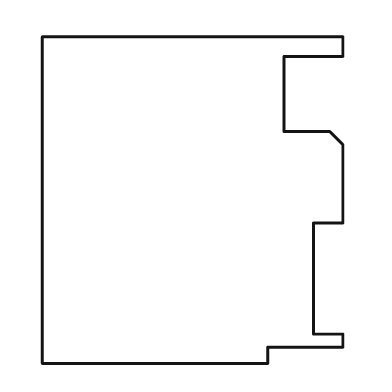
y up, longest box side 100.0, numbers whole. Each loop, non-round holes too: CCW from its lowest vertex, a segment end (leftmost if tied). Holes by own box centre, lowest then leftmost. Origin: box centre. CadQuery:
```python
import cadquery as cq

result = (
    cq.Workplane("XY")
    .moveTo(-46.0, -50.0)
    .lineTo(23.0, -50.0)
    .lineTo(23.0, -45.0)
    .lineTo(46.0, -45.0)
    .lineTo(46.0, -41.0)
    .lineTo(37.0, -41.0)
    .lineTo(37.0, -7.0)
    .lineTo(46.0, -7.0)
    .lineTo(46.0, 17.0)
    .lineTo(42.0, 21.0)
    .lineTo(28.0, 21.0)
    .lineTo(28.0, 44.0)
    .lineTo(46.0, 44.0)
    .lineTo(46.0, 50.0)
    .lineTo(-46.0, 50.0)
    .close()
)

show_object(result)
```